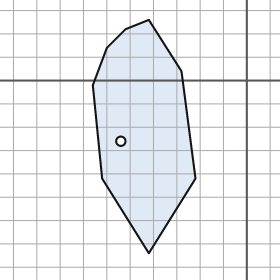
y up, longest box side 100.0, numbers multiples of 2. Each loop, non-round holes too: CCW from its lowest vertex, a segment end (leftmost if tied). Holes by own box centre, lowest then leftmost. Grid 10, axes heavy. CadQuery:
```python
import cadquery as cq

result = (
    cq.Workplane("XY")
    .moveTo(-42.0, -74.0)
    .lineTo(-22.0, -42.0)
    .lineTo(-28.0, 4.0)
    .lineTo(-42.0, 26.0)
    .lineTo(-52.0, 22.0)
    .lineTo(-60.0, 14.0)
    .lineTo(-66.0, -2.0)
    .lineTo(-62.0, -42.0)
    .close()
    .moveTo(-54.0, -26.0)
    .circle(2.0)
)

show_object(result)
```